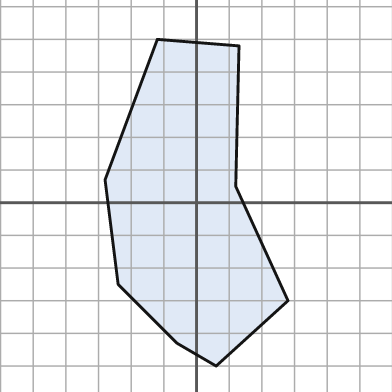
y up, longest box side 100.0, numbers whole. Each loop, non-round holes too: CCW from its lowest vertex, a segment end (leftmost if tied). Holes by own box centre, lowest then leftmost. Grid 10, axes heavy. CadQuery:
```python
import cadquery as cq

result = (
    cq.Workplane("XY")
    .moveTo(6.0, -50.0)
    .lineTo(28.0, -30.0)
    .lineTo(12.0, 5.0)
    .lineTo(13.0, 48.0)
    .lineTo(-12.0, 50.0)
    .lineTo(-28.0, 7.0)
    .lineTo(-24.0, -25.0)
    .lineTo(-6.0, -43.0)
    .close()
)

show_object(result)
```